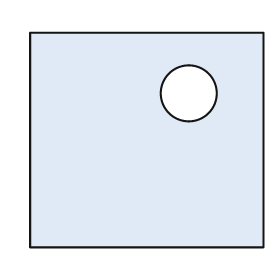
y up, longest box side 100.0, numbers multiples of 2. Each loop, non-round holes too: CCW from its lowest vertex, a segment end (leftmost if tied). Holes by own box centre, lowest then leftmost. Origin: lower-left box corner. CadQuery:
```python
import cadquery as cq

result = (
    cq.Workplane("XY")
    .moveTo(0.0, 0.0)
    .lineTo(100.0, 0.0)
    .lineTo(100.0, 92.0)
    .lineTo(0.0, 92.0)
    .close()
    .moveTo(68.0, 66.0)
    .circle(12.0)
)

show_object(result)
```